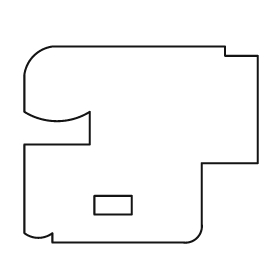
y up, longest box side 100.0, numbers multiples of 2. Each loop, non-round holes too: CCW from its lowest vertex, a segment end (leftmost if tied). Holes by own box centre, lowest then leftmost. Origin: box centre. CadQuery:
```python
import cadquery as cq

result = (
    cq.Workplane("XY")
    .moveTo(-38.0, -42.0)
    .lineTo(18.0, -42.0)
    .threePointArc((24.0, -40.0), (26.0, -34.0))
    .lineTo(26.0, -8.0)
    .lineTo(50.0, -8.0)
    .lineTo(50.0, 38.0)
    .lineTo(36.0, 38.0)
    .lineTo(36.0, 42.0)
    .lineTo(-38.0, 42.0)
    .threePointArc((-46.0, 38.0), (-50.0, 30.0))
    .lineTo(-50.0, 14.0)
    .threePointArc((-36.0, 10.0), (-22.0, 14.0))
    .lineTo(-22.0, 0.0)
    .lineTo(-50.0, 0.0)
    .lineTo(-50.0, -38.0)
    .threePointArc((-44.0, -40.0), (-38.0, -38.0))
    .close()
    .moveTo(-20.0, -30.0)
    .lineTo(-4.0, -30.0)
    .lineTo(-4.0, -22.0)
    .lineTo(-20.0, -22.0)
    .close()
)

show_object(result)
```